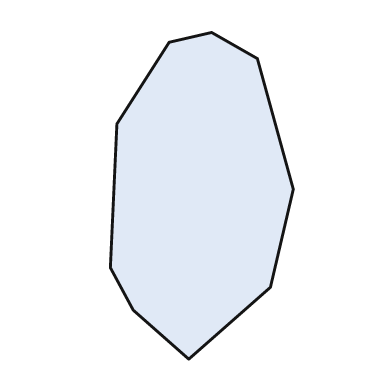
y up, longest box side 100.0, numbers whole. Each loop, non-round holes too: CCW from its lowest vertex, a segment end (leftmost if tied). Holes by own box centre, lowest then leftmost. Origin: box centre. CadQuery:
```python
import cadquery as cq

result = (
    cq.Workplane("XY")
    .moveTo(-4.0, -50.0)
    .lineTo(21.0, -28.0)
    .lineTo(28.0, 2.0)
    .lineTo(17.0, 42.0)
    .lineTo(3.0, 50.0)
    .lineTo(-10.0, 47.0)
    .lineTo(-26.0, 22.0)
    .lineTo(-28.0, -22.0)
    .lineTo(-21.0, -35.0)
    .close()
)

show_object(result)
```